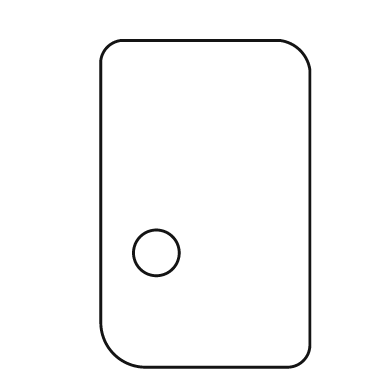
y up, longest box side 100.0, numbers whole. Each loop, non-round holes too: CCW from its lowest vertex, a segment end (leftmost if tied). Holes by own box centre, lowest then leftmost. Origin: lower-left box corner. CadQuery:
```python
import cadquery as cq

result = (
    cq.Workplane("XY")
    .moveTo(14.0, 0.0)
    .lineTo(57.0, 0.0)
    .threePointArc((62.0, 2.0), (64.0, 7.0))
    .lineTo(64.0, 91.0)
    .threePointArc((61.0, 97.0), (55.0, 100.0))
    .lineTo(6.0, 100.0)
    .threePointArc((2.0, 98.0), (0.0, 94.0))
    .lineTo(0.0, 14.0)
    .threePointArc((4.0, 4.0), (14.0, 0.0))
    .close()
    .moveTo(17.0, 35.0)
    .circle(7.0)
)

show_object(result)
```